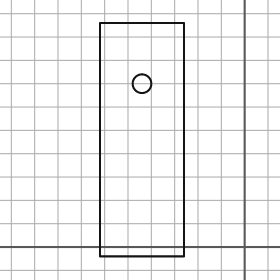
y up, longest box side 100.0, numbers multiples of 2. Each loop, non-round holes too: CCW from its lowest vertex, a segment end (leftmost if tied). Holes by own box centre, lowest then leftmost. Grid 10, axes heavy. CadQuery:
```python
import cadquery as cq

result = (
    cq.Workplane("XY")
    .moveTo(-62.0, -4.0)
    .lineTo(-26.0, -4.0)
    .lineTo(-26.0, 96.0)
    .lineTo(-62.0, 96.0)
    .close()
    .moveTo(-44.0, 70.0)
    .circle(4.0)
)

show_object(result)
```